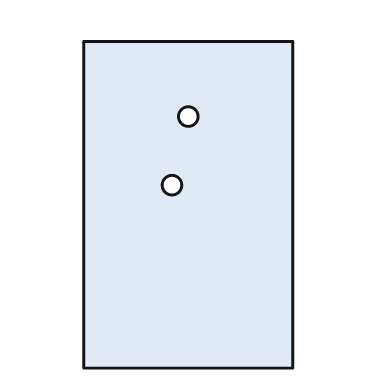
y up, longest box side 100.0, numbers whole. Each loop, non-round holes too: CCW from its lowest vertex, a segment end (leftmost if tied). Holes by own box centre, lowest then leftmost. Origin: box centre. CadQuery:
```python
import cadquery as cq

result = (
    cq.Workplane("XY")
    .moveTo(-32.0, -50.0)
    .lineTo(32.0, -50.0)
    .lineTo(32.0, 50.0)
    .lineTo(-32.0, 50.0)
    .close()
    .moveTo(-5.0, 6.0)
    .circle(3.0)
    .moveTo(0.0, 27.0)
    .circle(3.0)
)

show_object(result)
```